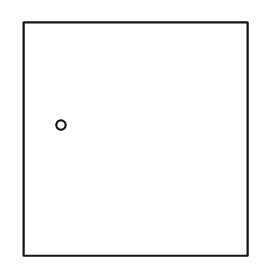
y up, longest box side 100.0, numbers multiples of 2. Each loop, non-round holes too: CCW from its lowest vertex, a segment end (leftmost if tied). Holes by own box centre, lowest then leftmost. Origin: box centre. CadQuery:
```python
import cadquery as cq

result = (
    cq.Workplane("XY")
    .moveTo(-48.0, -50.0)
    .lineTo(48.0, -50.0)
    .lineTo(48.0, 50.0)
    .lineTo(-48.0, 50.0)
    .close()
    .moveTo(-32.0, 6.0)
    .circle(2.0)
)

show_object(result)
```